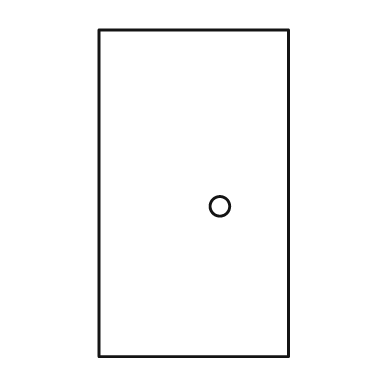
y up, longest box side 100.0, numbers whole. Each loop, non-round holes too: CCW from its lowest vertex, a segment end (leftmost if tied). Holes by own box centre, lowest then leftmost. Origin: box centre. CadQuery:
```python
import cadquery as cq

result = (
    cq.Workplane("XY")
    .moveTo(-29.0, -50.0)
    .lineTo(29.0, -50.0)
    .lineTo(29.0, 50.0)
    .lineTo(-29.0, 50.0)
    .close()
    .moveTo(8.0, -4.0)
    .circle(3.0)
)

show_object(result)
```